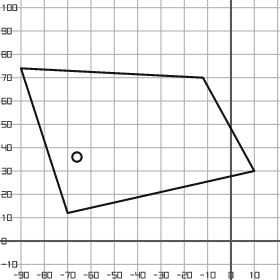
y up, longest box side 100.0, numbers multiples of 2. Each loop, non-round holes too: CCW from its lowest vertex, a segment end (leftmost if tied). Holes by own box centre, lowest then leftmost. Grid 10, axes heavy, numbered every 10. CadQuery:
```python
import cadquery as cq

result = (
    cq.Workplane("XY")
    .moveTo(-70.0, 12.0)
    .lineTo(10.0, 30.0)
    .lineTo(-12.0, 70.0)
    .lineTo(-90.0, 74.0)
    .close()
    .moveTo(-66.0, 36.0)
    .circle(2.0)
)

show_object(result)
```